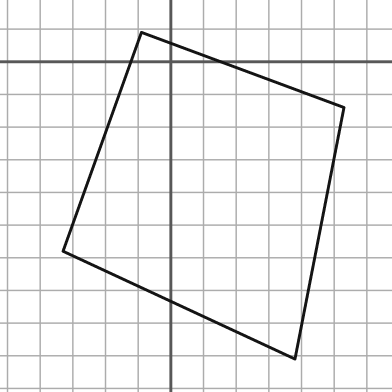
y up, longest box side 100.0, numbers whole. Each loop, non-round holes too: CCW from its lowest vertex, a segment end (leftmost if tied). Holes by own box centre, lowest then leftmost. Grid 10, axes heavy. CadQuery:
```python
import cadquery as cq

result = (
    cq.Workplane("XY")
    .moveTo(38.0, -91.0)
    .lineTo(53.0, -14.0)
    .lineTo(-9.0, 9.0)
    .lineTo(-33.0, -58.0)
    .close()
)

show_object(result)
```